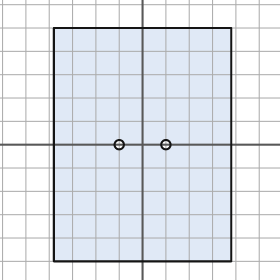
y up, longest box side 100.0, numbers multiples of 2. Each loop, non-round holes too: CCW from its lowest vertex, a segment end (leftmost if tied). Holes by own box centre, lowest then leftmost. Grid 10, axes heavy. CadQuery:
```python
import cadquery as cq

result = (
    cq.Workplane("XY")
    .moveTo(-38.0, -50.0)
    .lineTo(38.0, -50.0)
    .lineTo(38.0, 50.0)
    .lineTo(-38.0, 50.0)
    .close()
    .moveTo(-10.0, 0.0)
    .circle(2.0)
    .moveTo(10.0, 0.0)
    .circle(2.0)
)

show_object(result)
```